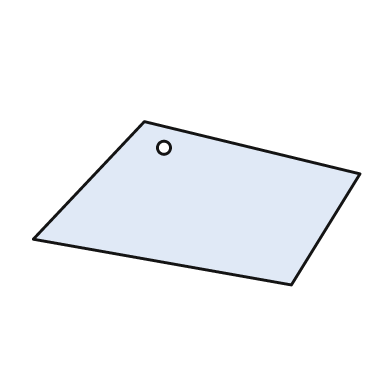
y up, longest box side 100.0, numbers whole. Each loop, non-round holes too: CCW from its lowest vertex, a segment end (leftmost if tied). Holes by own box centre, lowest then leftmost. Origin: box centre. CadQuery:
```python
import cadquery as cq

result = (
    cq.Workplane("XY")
    .moveTo(29.0, -25.0)
    .lineTo(50.0, 9.0)
    .lineTo(-16.0, 25.0)
    .lineTo(-50.0, -11.0)
    .close()
    .moveTo(-10.0, 17.0)
    .circle(2.0)
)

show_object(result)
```